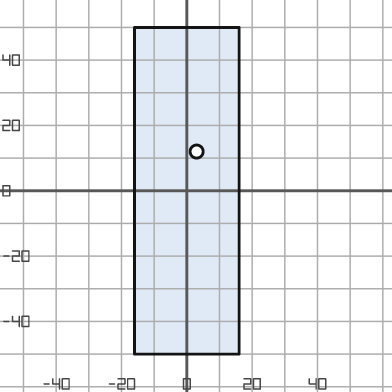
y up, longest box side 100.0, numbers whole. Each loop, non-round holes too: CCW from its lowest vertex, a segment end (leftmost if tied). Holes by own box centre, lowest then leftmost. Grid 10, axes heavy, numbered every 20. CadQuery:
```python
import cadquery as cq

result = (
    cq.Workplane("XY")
    .moveTo(-16.0, -50.0)
    .lineTo(16.0, -50.0)
    .lineTo(16.0, 50.0)
    .lineTo(-16.0, 50.0)
    .close()
    .moveTo(3.0, 12.0)
    .circle(2.0)
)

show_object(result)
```